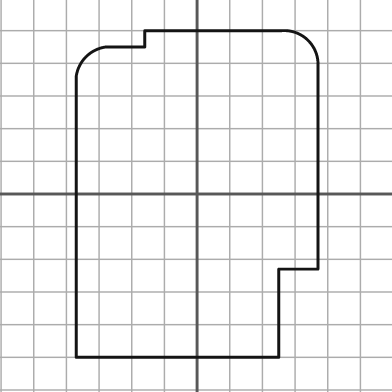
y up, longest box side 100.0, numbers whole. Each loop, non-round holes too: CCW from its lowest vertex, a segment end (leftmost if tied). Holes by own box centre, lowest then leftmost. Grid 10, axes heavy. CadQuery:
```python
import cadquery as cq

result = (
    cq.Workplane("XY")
    .moveTo(-37.0, -50.0)
    .lineTo(25.0, -50.0)
    .lineTo(25.0, -23.0)
    .lineTo(37.0, -23.0)
    .lineTo(37.0, 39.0)
    .threePointArc((34.0, 47.0), (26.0, 50.0))
    .lineTo(-16.0, 50.0)
    .lineTo(-16.0, 45.0)
    .lineTo(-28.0, 45.0)
    .threePointArc((-34.0, 42.0), (-37.0, 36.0))
    .close()
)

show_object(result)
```